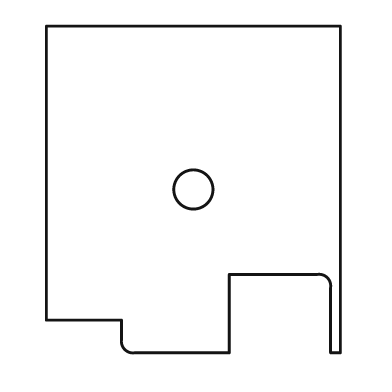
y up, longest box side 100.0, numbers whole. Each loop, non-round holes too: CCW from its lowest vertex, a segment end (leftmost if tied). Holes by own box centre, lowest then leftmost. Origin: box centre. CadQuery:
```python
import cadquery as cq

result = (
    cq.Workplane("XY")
    .moveTo(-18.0, -50.0)
    .lineTo(11.0, -50.0)
    .lineTo(11.0, -26.0)
    .lineTo(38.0, -26.0)
    .threePointArc((41.0, -27.0), (42.0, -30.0))
    .lineTo(42.0, -50.0)
    .lineTo(45.0, -50.0)
    .lineTo(45.0, 50.0)
    .lineTo(-45.0, 50.0)
    .lineTo(-45.0, -40.0)
    .lineTo(-22.0, -40.0)
    .lineTo(-22.0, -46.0)
    .threePointArc((-21.0, -49.0), (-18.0, -50.0))
    .close()
    .moveTo(0.0, 0.0)
    .circle(6.0)
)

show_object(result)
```